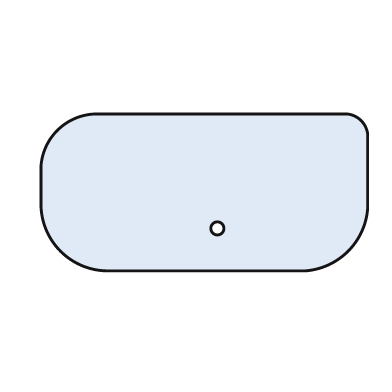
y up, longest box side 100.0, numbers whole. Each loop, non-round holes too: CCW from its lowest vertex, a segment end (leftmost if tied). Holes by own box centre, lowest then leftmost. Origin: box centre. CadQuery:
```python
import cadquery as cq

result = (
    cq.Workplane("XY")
    .moveTo(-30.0, -24.0)
    .lineTo(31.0, -24.0)
    .threePointArc((44.0, -18.0), (50.0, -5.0))
    .lineTo(50.0, 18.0)
    .threePointArc((48.0, 22.0), (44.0, 24.0))
    .lineTo(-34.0, 24.0)
    .threePointArc((-45.0, 19.0), (-50.0, 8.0))
    .lineTo(-50.0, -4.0)
    .threePointArc((-44.0, -18.0), (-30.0, -24.0))
    .close()
    .moveTo(4.0, -11.0)
    .circle(2.0)
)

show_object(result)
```